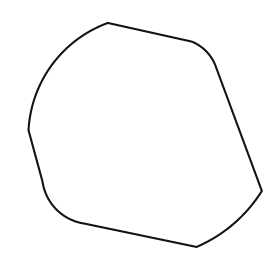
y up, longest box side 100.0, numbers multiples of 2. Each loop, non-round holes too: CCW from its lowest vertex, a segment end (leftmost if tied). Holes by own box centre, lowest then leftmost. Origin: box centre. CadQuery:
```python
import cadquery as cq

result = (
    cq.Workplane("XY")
    .moveTo(22.0, -48.0)
    .threePointArc((38.0, -38.0), (50.0, -24.0))
    .lineTo(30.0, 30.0)
    .threePointArc((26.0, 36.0), (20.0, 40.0))
    .lineTo(-16.0, 48.0)
    .threePointArc((-40.0, 30.0), (-50.0, 2.0))
    .lineTo(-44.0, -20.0)
    .threePointArc((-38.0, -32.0), (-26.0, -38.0))
    .close()
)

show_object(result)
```